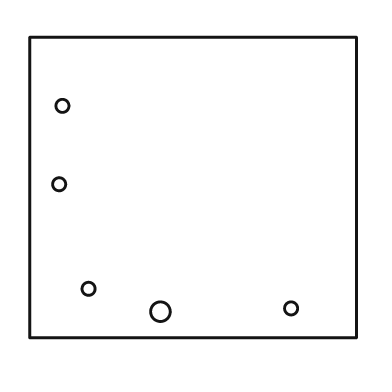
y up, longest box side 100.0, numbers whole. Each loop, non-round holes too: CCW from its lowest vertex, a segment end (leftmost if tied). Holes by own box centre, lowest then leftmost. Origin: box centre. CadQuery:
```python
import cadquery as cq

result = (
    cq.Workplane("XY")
    .moveTo(-50.0, -46.0)
    .lineTo(50.0, -46.0)
    .lineTo(50.0, 46.0)
    .lineTo(-50.0, 46.0)
    .close()
    .moveTo(-10.0, -38.0)
    .circle(3.0)
    .moveTo(30.0, -37.0)
    .circle(2.0)
    .moveTo(-32.0, -31.0)
    .circle(2.0)
    .moveTo(-41.0, 1.0)
    .circle(2.0)
    .moveTo(-40.0, 25.0)
    .circle(2.0)
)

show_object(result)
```